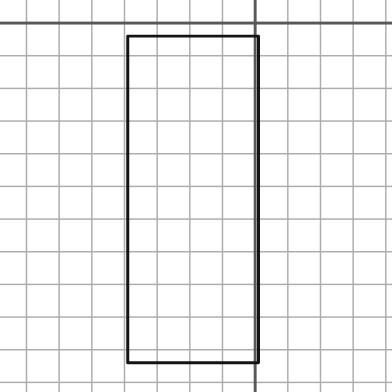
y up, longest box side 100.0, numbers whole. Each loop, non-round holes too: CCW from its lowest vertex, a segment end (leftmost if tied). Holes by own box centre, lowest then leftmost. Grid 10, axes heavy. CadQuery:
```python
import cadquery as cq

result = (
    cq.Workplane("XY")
    .moveTo(-39.0, -104.0)
    .lineTo(1.0, -104.0)
    .lineTo(1.0, -4.0)
    .lineTo(-39.0, -4.0)
    .close()
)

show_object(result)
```